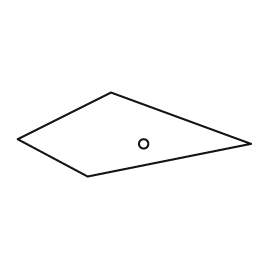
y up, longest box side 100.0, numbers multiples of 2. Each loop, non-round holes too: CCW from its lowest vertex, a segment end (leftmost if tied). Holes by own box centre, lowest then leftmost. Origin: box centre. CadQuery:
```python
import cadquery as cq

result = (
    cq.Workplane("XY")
    .moveTo(-20.0, -18.0)
    .lineTo(50.0, -4.0)
    .lineTo(-10.0, 18.0)
    .lineTo(-50.0, -2.0)
    .close()
    .moveTo(4.0, -4.0)
    .circle(2.0)
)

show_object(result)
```